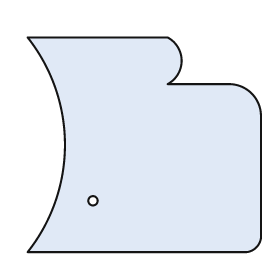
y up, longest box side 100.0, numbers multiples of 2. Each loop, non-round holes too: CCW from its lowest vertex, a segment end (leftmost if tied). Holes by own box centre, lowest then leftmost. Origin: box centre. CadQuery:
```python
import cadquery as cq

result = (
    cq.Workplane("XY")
    .moveTo(-50.0, -46.0)
    .lineTo(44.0, -46.0)
    .threePointArc((48.0, -44.0), (50.0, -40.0))
    .lineTo(50.0, 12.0)
    .threePointArc((46.0, 22.0), (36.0, 26.0))
    .lineTo(10.0, 26.0)
    .threePointArc((16.0, 36.0), (10.0, 46.0))
    .lineTo(-50.0, 46.0)
    .threePointArc((-34.0, 0.0), (-50.0, -46.0))
    .close()
    .moveTo(-22.0, -24.0)
    .circle(2.0)
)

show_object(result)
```